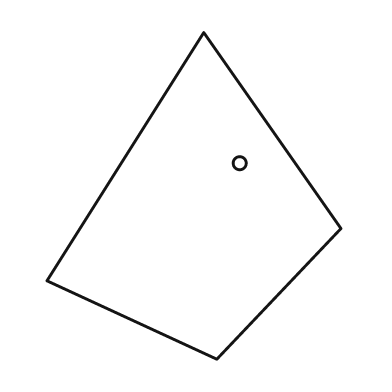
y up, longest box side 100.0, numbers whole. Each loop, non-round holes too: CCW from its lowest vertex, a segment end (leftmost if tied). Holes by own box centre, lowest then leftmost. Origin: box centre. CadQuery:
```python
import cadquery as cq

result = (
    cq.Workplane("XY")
    .moveTo(7.0, -50.0)
    .lineTo(45.0, -10.0)
    .lineTo(3.0, 50.0)
    .lineTo(-45.0, -26.0)
    .close()
    .moveTo(14.0, 10.0)
    .circle(2.0)
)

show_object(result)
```